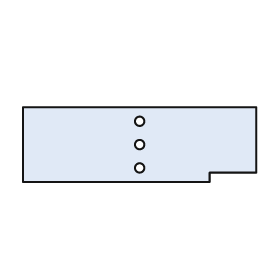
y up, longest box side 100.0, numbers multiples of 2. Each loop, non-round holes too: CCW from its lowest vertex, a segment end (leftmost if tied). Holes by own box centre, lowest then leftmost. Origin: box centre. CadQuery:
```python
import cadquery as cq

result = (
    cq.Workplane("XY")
    .moveTo(-50.0, -16.0)
    .lineTo(30.0, -16.0)
    .lineTo(30.0, -12.0)
    .lineTo(50.0, -12.0)
    .lineTo(50.0, 16.0)
    .lineTo(-50.0, 16.0)
    .close()
    .moveTo(0.0, -10.0)
    .circle(2.0)
    .moveTo(0.0, 0.0)
    .circle(2.0)
    .moveTo(0.0, 10.0)
    .circle(2.0)
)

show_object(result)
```